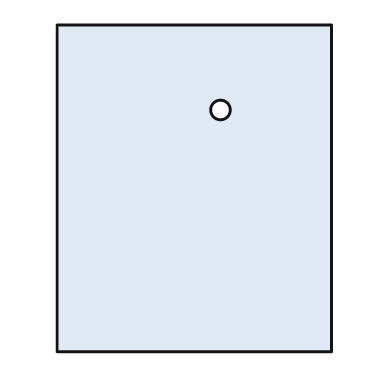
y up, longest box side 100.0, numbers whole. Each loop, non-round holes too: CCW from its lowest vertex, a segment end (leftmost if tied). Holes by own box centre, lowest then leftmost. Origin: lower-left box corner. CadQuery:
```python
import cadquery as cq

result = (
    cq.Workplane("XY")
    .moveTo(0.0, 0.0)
    .lineTo(84.0, 0.0)
    .lineTo(84.0, 100.0)
    .lineTo(0.0, 100.0)
    .close()
    .moveTo(50.0, 74.0)
    .circle(3.0)
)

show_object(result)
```